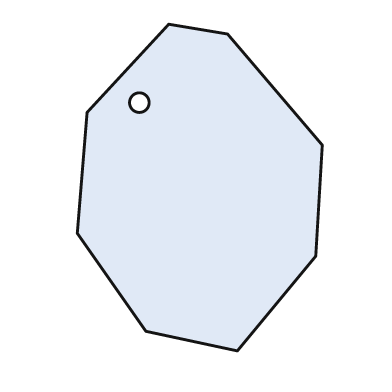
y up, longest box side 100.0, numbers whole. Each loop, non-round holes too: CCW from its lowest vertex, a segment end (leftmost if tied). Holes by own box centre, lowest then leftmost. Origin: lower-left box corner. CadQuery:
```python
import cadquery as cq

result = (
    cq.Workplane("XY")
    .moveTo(49.0, 0.0)
    .lineTo(73.0, 29.0)
    .lineTo(75.0, 63.0)
    .lineTo(46.0, 97.0)
    .lineTo(28.0, 100.0)
    .lineTo(3.0, 73.0)
    .lineTo(0.0, 36.0)
    .lineTo(21.0, 6.0)
    .close()
    .moveTo(19.0, 76.0)
    .circle(3.0)
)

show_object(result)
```